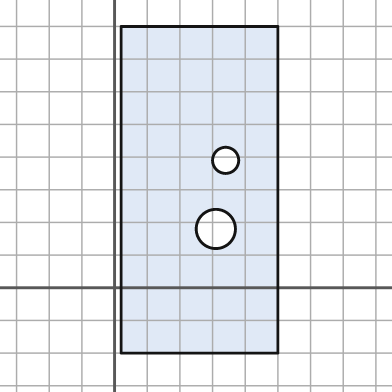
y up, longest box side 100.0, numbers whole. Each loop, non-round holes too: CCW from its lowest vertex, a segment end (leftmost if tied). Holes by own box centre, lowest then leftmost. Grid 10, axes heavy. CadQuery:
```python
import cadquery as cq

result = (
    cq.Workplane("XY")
    .moveTo(2.0, -20.0)
    .lineTo(50.0, -20.0)
    .lineTo(50.0, 80.0)
    .lineTo(2.0, 80.0)
    .close()
    .moveTo(31.0, 18.0)
    .circle(6.0)
    .moveTo(34.0, 39.0)
    .circle(4.0)
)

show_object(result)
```